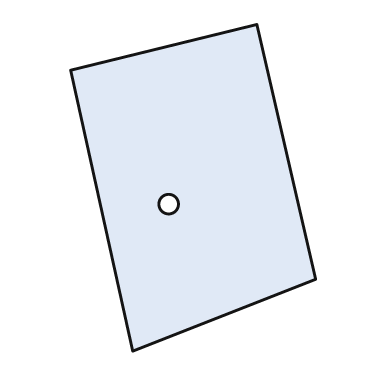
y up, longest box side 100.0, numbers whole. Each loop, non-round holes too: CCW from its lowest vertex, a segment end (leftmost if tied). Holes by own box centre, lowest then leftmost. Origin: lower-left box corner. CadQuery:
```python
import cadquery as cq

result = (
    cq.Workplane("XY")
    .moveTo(19.0, 0.0)
    .lineTo(75.0, 22.0)
    .lineTo(57.0, 100.0)
    .lineTo(0.0, 86.0)
    .close()
    .moveTo(30.0, 45.0)
    .circle(3.0)
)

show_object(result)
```